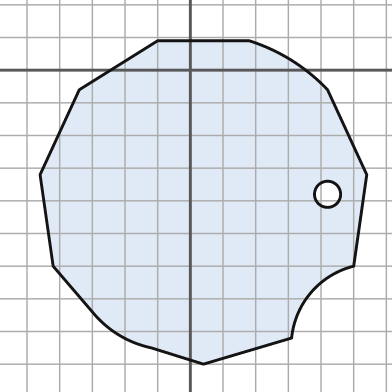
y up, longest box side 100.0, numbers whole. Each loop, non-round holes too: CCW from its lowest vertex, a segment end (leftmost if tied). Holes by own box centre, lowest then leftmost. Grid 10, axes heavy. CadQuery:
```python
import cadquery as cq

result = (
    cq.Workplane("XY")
    .moveTo(4.0, -90.0)
    .lineTo(31.0, -82.0)
    .threePointArc((37.0, -68.0), (50.0, -60.0))
    .lineTo(54.0, -32.0)
    .lineTo(42.0, -6.0)
    .threePointArc((31.0, 3.0), (18.0, 9.0))
    .lineTo(-10.0, 9.0)
    .lineTo(-34.0, -6.0)
    .lineTo(-46.0, -32.0)
    .lineTo(-42.0, -60.0)
    .lineTo(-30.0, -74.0)
    .threePointArc((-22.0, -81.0), (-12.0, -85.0))
    .close()
    .moveTo(42.0, -38.0)
    .circle(4.0)
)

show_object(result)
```